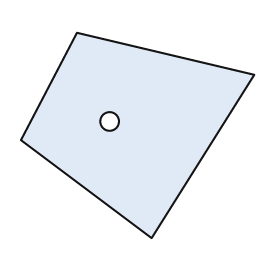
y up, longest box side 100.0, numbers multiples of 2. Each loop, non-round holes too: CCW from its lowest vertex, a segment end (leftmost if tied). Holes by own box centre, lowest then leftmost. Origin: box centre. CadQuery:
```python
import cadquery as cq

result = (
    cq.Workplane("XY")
    .moveTo(6.0, -44.0)
    .lineTo(50.0, 26.0)
    .lineTo(-26.0, 44.0)
    .lineTo(-50.0, -2.0)
    .close()
    .moveTo(-12.0, 6.0)
    .circle(4.0)
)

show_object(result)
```